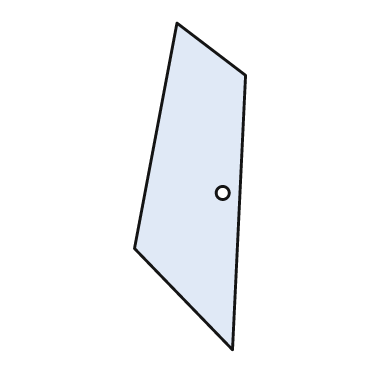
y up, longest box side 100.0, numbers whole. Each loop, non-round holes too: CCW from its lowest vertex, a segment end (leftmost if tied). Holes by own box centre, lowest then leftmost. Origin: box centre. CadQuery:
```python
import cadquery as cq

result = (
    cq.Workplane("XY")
    .moveTo(13.0, -50.0)
    .lineTo(17.0, 34.0)
    .lineTo(-4.0, 50.0)
    .lineTo(-17.0, -19.0)
    .close()
    .moveTo(10.0, -2.0)
    .circle(2.0)
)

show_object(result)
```